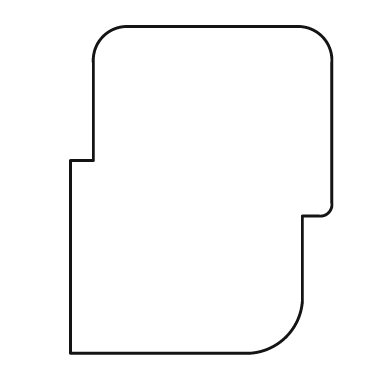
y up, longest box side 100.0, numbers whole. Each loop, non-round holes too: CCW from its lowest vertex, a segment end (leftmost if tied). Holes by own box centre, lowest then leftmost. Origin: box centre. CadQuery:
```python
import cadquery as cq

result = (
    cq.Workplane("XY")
    .moveTo(-40.0, -50.0)
    .lineTo(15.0, -50.0)
    .threePointArc((26.0, -45.0), (31.0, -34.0))
    .lineTo(31.0, -8.0)
    .lineTo(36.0, -8.0)
    .threePointArc((39.0, -7.0), (40.0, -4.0))
    .lineTo(40.0, 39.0)
    .threePointArc((37.0, 47.0), (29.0, 50.0))
    .lineTo(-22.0, 50.0)
    .threePointArc((-30.0, 47.0), (-33.0, 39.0))
    .lineTo(-33.0, 9.0)
    .lineTo(-40.0, 9.0)
    .close()
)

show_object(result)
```